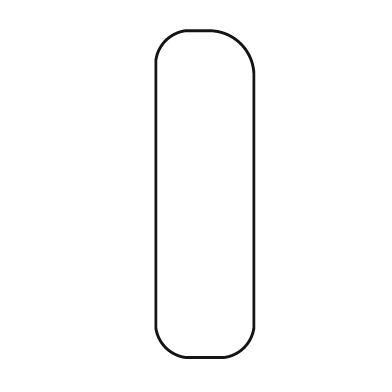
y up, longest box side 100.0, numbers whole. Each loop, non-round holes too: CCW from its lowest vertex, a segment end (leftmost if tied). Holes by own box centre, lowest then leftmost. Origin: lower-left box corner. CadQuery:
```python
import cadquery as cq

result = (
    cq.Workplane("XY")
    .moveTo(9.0, 0.0)
    .lineTo(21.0, 0.0)
    .threePointArc((27.0, 3.0), (30.0, 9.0))
    .lineTo(30.0, 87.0)
    .threePointArc((26.0, 96.0), (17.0, 100.0))
    .lineTo(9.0, 100.0)
    .threePointArc((3.0, 97.0), (0.0, 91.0))
    .lineTo(0.0, 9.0)
    .threePointArc((3.0, 3.0), (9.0, 0.0))
    .close()
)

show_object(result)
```